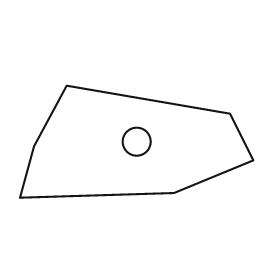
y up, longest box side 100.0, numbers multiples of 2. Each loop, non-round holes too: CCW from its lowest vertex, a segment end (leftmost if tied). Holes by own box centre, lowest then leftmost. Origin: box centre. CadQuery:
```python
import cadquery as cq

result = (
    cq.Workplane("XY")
    .moveTo(-50.0, -24.0)
    .lineTo(16.0, -22.0)
    .lineTo(50.0, -8.0)
    .lineTo(40.0, 12.0)
    .lineTo(-30.0, 24.0)
    .lineTo(-44.0, -2.0)
    .close()
    .moveTo(0.0, 0.0)
    .circle(6.0)
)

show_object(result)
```